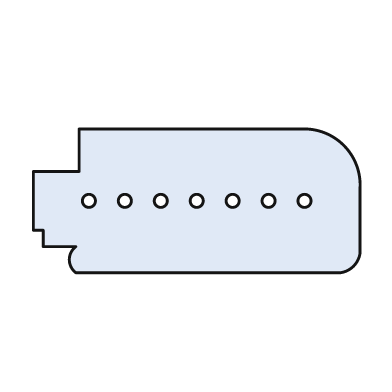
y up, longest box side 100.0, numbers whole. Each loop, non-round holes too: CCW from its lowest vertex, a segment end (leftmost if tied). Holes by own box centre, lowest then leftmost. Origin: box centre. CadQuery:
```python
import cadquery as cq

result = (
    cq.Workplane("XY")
    .moveTo(-37.0, -22.0)
    .lineTo(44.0, -22.0)
    .threePointArc((48.0, -20.0), (50.0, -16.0))
    .lineTo(50.0, 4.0)
    .threePointArc((45.0, 17.0), (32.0, 22.0))
    .lineTo(-36.0, 22.0)
    .lineTo(-36.0, 9.0)
    .lineTo(-50.0, 9.0)
    .lineTo(-50.0, -9.0)
    .lineTo(-47.0, -9.0)
    .lineTo(-47.0, -14.0)
    .lineTo(-37.0, -14.0)
    .threePointArc((-39.0, -18.0), (-37.0, -22.0))
    .close()
    .moveTo(-33.0, 0.0)
    .circle(2.0)
    .moveTo(-22.0, 0.0)
    .circle(2.0)
    .moveTo(-11.0, 0.0)
    .circle(2.0)
    .moveTo(0.0, 0.0)
    .circle(2.0)
    .moveTo(11.0, 0.0)
    .circle(2.0)
    .moveTo(22.0, 0.0)
    .circle(2.0)
    .moveTo(33.0, 0.0)
    .circle(2.0)
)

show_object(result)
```